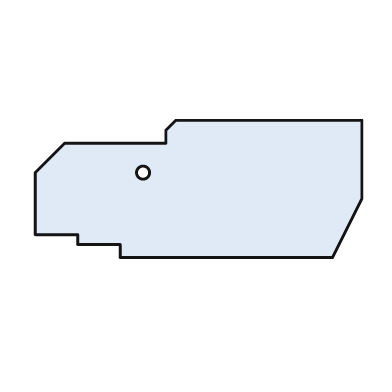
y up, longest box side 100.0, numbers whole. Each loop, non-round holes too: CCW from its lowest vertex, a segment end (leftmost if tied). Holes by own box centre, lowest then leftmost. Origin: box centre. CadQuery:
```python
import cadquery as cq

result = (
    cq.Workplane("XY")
    .moveTo(-24.0, -21.0)
    .lineTo(41.0, -21.0)
    .lineTo(50.0, -3.0)
    .lineTo(50.0, 21.0)
    .lineTo(-7.0, 21.0)
    .lineTo(-10.0, 18.0)
    .lineTo(-10.0, 14.0)
    .lineTo(-41.0, 14.0)
    .lineTo(-50.0, 5.0)
    .lineTo(-50.0, -14.0)
    .lineTo(-37.0, -14.0)
    .lineTo(-37.0, -17.0)
    .lineTo(-24.0, -17.0)
    .close()
    .moveTo(-17.0, 5.0)
    .circle(2.0)
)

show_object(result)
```